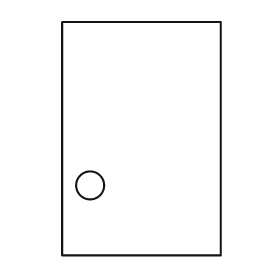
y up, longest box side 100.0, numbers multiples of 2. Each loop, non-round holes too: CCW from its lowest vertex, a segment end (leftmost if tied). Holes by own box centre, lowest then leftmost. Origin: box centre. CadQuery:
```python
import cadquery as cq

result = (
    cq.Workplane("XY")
    .moveTo(-34.0, -50.0)
    .lineTo(34.0, -50.0)
    .lineTo(34.0, 50.0)
    .lineTo(-34.0, 50.0)
    .close()
    .moveTo(-22.0, -20.0)
    .circle(6.0)
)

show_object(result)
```